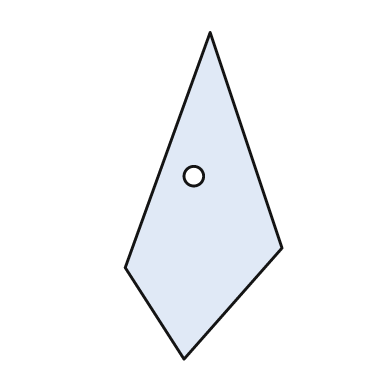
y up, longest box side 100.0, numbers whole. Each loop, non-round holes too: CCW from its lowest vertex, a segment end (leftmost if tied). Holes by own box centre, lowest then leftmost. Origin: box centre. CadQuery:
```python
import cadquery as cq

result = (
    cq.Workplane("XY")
    .moveTo(-6.0, -50.0)
    .lineTo(24.0, -16.0)
    .lineTo(2.0, 50.0)
    .lineTo(-24.0, -22.0)
    .close()
    .moveTo(-3.0, 6.0)
    .circle(3.0)
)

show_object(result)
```